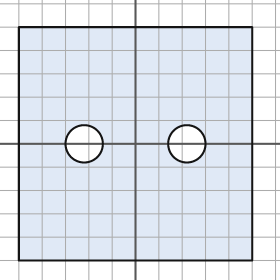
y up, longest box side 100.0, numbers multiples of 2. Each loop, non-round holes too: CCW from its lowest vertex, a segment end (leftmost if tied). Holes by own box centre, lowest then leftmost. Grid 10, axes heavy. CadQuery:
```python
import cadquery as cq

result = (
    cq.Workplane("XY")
    .moveTo(-50.0, -50.0)
    .lineTo(50.0, -50.0)
    .lineTo(50.0, 50.0)
    .lineTo(-50.0, 50.0)
    .close()
    .moveTo(-22.0, 0.0)
    .circle(8.0)
    .moveTo(22.0, 0.0)
    .circle(8.0)
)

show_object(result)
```